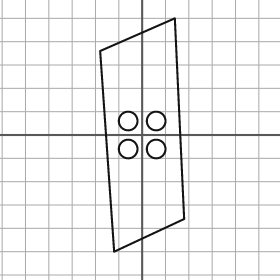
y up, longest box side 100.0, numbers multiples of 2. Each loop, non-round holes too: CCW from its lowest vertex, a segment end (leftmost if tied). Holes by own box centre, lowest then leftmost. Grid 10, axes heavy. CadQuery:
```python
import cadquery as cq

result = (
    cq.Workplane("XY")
    .moveTo(-12.0, -50.0)
    .lineTo(18.0, -36.0)
    .lineTo(14.0, 50.0)
    .lineTo(-18.0, 36.0)
    .close()
    .moveTo(-6.0, -6.0)
    .circle(4.0)
    .moveTo(6.0, -6.0)
    .circle(4.0)
    .moveTo(-6.0, 6.0)
    .circle(4.0)
    .moveTo(6.0, 6.0)
    .circle(4.0)
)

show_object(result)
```